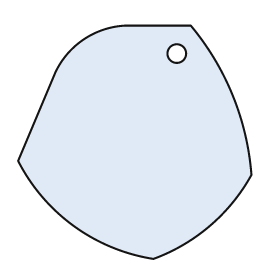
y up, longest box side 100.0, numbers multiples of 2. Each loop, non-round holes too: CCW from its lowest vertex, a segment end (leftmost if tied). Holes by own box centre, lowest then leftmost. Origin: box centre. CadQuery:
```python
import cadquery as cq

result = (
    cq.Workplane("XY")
    .moveTo(8.0, -50.0)
    .threePointArc((32.0, -36.0), (50.0, -14.0))
    .threePointArc((42.0, 20.0), (24.0, 50.0))
    .lineTo(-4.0, 50.0)
    .threePointArc((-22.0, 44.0), (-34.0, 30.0))
    .lineTo(-50.0, -8.0)
    .threePointArc((-26.0, -36.0), (8.0, -50.0))
    .close()
    .moveTo(18.0, 38.0)
    .circle(4.0)
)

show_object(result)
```